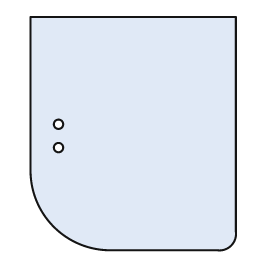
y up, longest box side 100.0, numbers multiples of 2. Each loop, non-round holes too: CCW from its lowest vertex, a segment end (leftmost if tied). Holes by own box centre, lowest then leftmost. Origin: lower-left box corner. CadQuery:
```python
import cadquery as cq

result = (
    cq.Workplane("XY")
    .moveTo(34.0, 0.0)
    .lineTo(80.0, 0.0)
    .threePointArc((86.0, 2.0), (88.0, 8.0))
    .lineTo(88.0, 100.0)
    .lineTo(0.0, 100.0)
    .lineTo(0.0, 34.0)
    .threePointArc((10.0, 10.0), (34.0, 0.0))
    .close()
    .moveTo(12.0, 44.0)
    .circle(2.0)
    .moveTo(12.0, 54.0)
    .circle(2.0)
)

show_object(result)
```